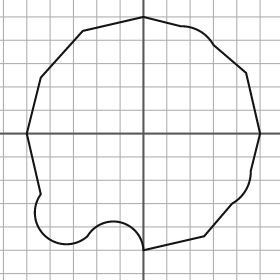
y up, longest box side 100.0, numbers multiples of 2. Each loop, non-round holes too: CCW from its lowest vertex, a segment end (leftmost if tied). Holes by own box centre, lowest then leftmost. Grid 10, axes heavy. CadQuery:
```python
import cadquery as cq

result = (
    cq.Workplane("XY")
    .moveTo(0.0, -50.0)
    .lineTo(26.0, -44.0)
    .lineTo(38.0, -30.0)
    .threePointArc((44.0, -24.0), (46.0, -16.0))
    .lineTo(50.0, 0.0)
    .lineTo(44.0, 26.0)
    .lineTo(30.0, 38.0)
    .threePointArc((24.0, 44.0), (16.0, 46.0))
    .lineTo(0.0, 50.0)
    .lineTo(-26.0, 44.0)
    .lineTo(-44.0, 24.0)
    .lineTo(-50.0, 0.0)
    .lineTo(-44.0, -26.0)
    .threePointArc((-42.0, -44.0), (-24.0, -44.0))
    .threePointArc((-10.0, -38.0), (0.0, -50.0))
    .close()
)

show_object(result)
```